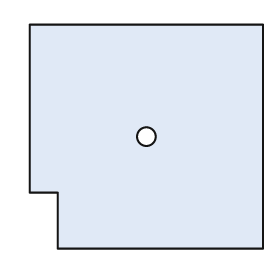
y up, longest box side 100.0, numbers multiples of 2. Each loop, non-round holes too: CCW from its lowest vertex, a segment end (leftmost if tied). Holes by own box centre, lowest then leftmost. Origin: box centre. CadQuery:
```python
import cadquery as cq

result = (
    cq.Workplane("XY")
    .moveTo(-38.0, -48.0)
    .lineTo(50.0, -48.0)
    .lineTo(50.0, 48.0)
    .lineTo(-50.0, 48.0)
    .lineTo(-50.0, -24.0)
    .lineTo(-38.0, -24.0)
    .close()
    .moveTo(0.0, 0.0)
    .circle(4.0)
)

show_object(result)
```